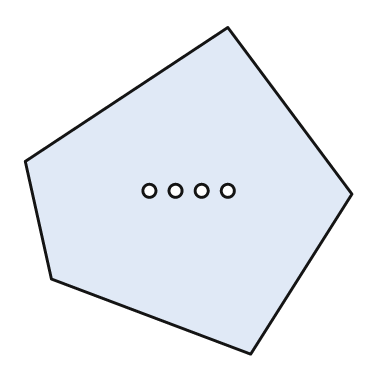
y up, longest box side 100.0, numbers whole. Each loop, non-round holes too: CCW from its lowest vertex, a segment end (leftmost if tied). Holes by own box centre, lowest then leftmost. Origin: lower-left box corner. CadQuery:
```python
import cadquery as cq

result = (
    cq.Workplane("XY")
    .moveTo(69.0, 0.0)
    .lineTo(100.0, 49.0)
    .lineTo(62.0, 100.0)
    .lineTo(0.0, 59.0)
    .lineTo(8.0, 23.0)
    .close()
    .moveTo(38.0, 50.0)
    .circle(2.0)
    .moveTo(46.0, 50.0)
    .circle(2.0)
    .moveTo(54.0, 50.0)
    .circle(2.0)
    .moveTo(62.0, 50.0)
    .circle(2.0)
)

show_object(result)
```